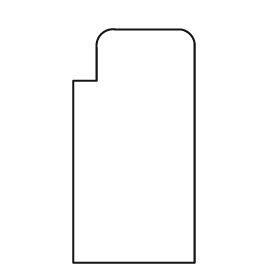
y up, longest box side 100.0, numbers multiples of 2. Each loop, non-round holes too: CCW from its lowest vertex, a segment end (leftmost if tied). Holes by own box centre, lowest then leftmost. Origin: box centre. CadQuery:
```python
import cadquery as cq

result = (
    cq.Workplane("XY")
    .moveTo(-26.0, -50.0)
    .lineTo(26.0, -50.0)
    .lineTo(26.0, 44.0)
    .threePointArc((24.0, 48.0), (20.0, 50.0))
    .lineTo(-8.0, 50.0)
    .threePointArc((-14.0, 48.0), (-16.0, 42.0))
    .lineTo(-16.0, 28.0)
    .lineTo(-26.0, 28.0)
    .close()
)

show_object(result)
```